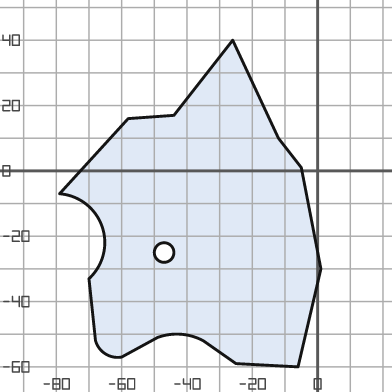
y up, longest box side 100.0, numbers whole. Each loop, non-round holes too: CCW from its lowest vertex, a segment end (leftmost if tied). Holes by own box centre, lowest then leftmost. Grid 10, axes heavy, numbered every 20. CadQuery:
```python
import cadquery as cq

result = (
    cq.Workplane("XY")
    .moveTo(-6.0, -60.0)
    .lineTo(1.0, -30.0)
    .lineTo(-5.0, 1.0)
    .lineTo(-12.0, 10.0)
    .lineTo(-26.0, 40.0)
    .lineTo(-44.0, 17.0)
    .lineTo(-58.0, 16.0)
    .lineTo(-79.0, -7.0)
    .threePointArc((-66.0, -17.0), (-70.0, -33.0))
    .lineTo(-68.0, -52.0)
    .threePointArc((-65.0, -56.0), (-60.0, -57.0))
    .lineTo(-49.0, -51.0)
    .threePointArc((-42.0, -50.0), (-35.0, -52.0))
    .lineTo(-25.0, -59.0)
    .close()
    .moveTo(-47.0, -25.0)
    .circle(3.0)
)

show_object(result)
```